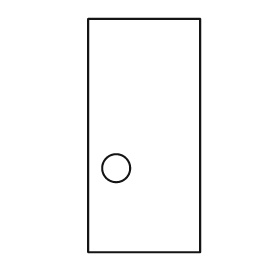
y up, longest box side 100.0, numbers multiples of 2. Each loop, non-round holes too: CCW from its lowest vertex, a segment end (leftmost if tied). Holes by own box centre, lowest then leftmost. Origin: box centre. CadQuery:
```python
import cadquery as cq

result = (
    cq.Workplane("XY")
    .moveTo(-24.0, -50.0)
    .lineTo(24.0, -50.0)
    .lineTo(24.0, 50.0)
    .lineTo(-24.0, 50.0)
    .close()
    .moveTo(-12.0, -14.0)
    .circle(6.0)
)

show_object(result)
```